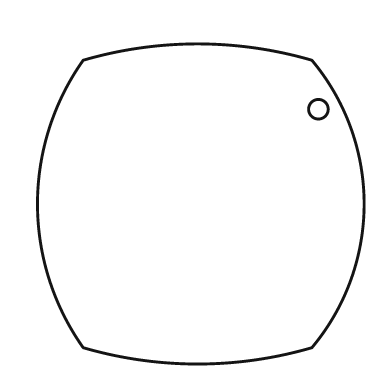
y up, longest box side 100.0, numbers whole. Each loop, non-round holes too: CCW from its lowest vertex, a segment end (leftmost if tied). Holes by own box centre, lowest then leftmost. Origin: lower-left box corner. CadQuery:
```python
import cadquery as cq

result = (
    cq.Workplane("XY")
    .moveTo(14.0, 5.0)
    .threePointArc((49.0, 0.0), (84.0, 5.0))
    .threePointArc((100.0, 49.0), (84.0, 93.0))
    .threePointArc((49.0, 98.0), (14.0, 93.0))
    .threePointArc((0.0, 49.0), (14.0, 5.0))
    .close()
    .moveTo(86.0, 78.0)
    .circle(3.0)
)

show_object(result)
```